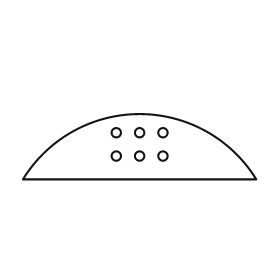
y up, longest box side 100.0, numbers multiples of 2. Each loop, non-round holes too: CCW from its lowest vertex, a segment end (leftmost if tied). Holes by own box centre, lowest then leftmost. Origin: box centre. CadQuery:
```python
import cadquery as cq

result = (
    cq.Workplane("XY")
    .moveTo(-50.0, -14.0)
    .lineTo(50.0, -14.0)
    .threePointArc((0.0, 14.0), (-50.0, -14.0))
    .close()
    .moveTo(-10.0, -4.0)
    .circle(2.0)
    .moveTo(0.0, -4.0)
    .circle(2.0)
    .moveTo(10.0, -4.0)
    .circle(2.0)
    .moveTo(-10.0, 6.0)
    .circle(2.0)
    .moveTo(0.0, 6.0)
    .circle(2.0)
    .moveTo(10.0, 6.0)
    .circle(2.0)
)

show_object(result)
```